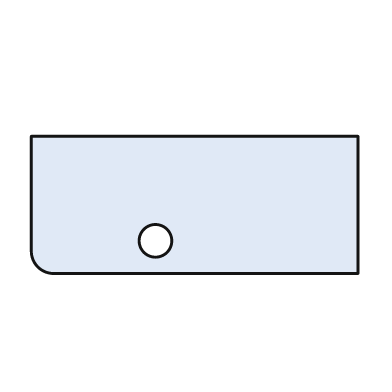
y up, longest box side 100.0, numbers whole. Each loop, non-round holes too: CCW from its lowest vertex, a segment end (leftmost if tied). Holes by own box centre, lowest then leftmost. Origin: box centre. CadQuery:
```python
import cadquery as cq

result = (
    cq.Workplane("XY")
    .moveTo(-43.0, -21.0)
    .lineTo(50.0, -21.0)
    .lineTo(50.0, 21.0)
    .lineTo(-50.0, 21.0)
    .lineTo(-50.0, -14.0)
    .threePointArc((-48.0, -19.0), (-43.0, -21.0))
    .close()
    .moveTo(-12.0, -11.0)
    .circle(5.0)
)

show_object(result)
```